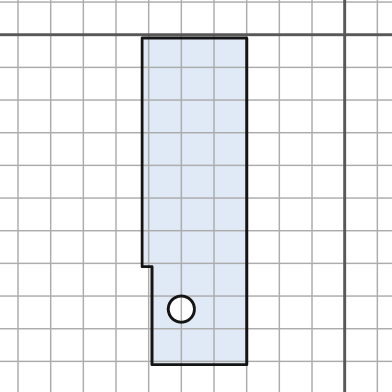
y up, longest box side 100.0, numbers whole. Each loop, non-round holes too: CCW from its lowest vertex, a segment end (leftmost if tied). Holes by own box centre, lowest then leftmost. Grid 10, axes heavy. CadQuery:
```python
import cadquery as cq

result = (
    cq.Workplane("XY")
    .moveTo(-59.0, -101.0)
    .lineTo(-30.0, -101.0)
    .lineTo(-30.0, -1.0)
    .lineTo(-62.0, -1.0)
    .lineTo(-62.0, -71.0)
    .lineTo(-59.0, -71.0)
    .close()
    .moveTo(-50.0, -84.0)
    .circle(4.0)
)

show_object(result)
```